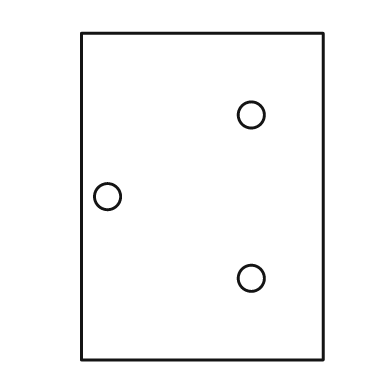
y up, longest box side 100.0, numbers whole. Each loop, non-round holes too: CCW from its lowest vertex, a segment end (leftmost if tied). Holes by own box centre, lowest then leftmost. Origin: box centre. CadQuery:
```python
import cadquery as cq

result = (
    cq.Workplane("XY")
    .moveTo(-37.0, -50.0)
    .lineTo(37.0, -50.0)
    .lineTo(37.0, 50.0)
    .lineTo(-37.0, 50.0)
    .close()
    .moveTo(15.0, -25.0)
    .circle(4.0)
    .moveTo(-29.0, 0.0)
    .circle(4.0)
    .moveTo(15.0, 25.0)
    .circle(4.0)
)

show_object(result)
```